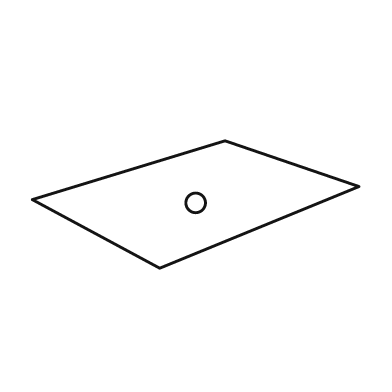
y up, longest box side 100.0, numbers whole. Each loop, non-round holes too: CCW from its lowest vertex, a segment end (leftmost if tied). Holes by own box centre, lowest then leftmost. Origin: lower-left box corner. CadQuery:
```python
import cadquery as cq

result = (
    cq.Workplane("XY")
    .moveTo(39.0, 0.0)
    .lineTo(100.0, 25.0)
    .lineTo(59.0, 39.0)
    .lineTo(0.0, 21.0)
    .close()
    .moveTo(50.0, 20.0)
    .circle(3.0)
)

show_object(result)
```